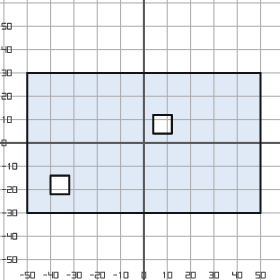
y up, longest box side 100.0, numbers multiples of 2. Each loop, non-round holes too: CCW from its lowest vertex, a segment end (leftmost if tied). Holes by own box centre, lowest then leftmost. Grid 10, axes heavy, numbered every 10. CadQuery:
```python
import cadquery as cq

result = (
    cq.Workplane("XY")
    .moveTo(-50.0, -30.0)
    .lineTo(50.0, -30.0)
    .lineTo(50.0, 30.0)
    .lineTo(-50.0, 30.0)
    .close()
    .moveTo(-40.0, -22.0)
    .lineTo(-32.0, -22.0)
    .lineTo(-32.0, -14.0)
    .lineTo(-40.0, -14.0)
    .close()
    .moveTo(4.0, 4.0)
    .lineTo(12.0, 4.0)
    .lineTo(12.0, 12.0)
    .lineTo(4.0, 12.0)
    .close()
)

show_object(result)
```